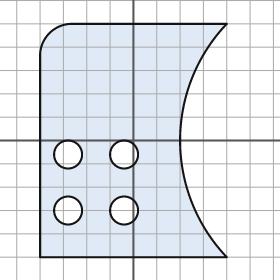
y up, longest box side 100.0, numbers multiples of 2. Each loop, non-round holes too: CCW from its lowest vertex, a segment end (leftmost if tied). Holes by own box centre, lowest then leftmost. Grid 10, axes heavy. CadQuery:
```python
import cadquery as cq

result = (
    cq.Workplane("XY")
    .moveTo(-40.0, -50.0)
    .lineTo(40.0, -50.0)
    .threePointArc((20.0, 0.0), (40.0, 50.0))
    .lineTo(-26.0, 50.0)
    .threePointArc((-36.0, 46.0), (-40.0, 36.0))
    .close()
    .moveTo(-28.0, -30.0)
    .circle(6.0)
    .moveTo(-4.0, -30.0)
    .circle(6.0)
    .moveTo(-28.0, -6.0)
    .circle(6.0)
    .moveTo(-4.0, -6.0)
    .circle(6.0)
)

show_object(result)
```